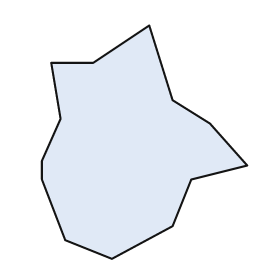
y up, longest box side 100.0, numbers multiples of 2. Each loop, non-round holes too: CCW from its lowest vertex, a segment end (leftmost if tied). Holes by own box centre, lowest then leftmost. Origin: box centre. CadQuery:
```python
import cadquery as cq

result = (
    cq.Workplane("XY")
    .moveTo(-14.0, -50.0)
    .lineTo(12.0, -36.0)
    .lineTo(20.0, -16.0)
    .lineTo(44.0, -10.0)
    .lineTo(28.0, 8.0)
    .lineTo(12.0, 18.0)
    .lineTo(2.0, 50.0)
    .lineTo(-22.0, 34.0)
    .lineTo(-40.0, 34.0)
    .lineTo(-36.0, 10.0)
    .lineTo(-44.0, -8.0)
    .lineTo(-44.0, -16.0)
    .lineTo(-34.0, -42.0)
    .close()
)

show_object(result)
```